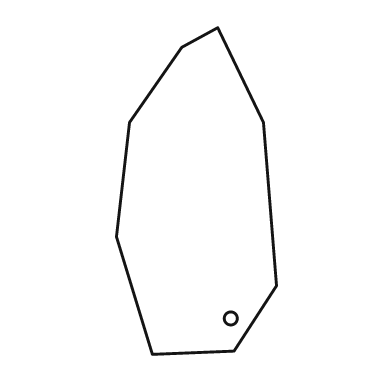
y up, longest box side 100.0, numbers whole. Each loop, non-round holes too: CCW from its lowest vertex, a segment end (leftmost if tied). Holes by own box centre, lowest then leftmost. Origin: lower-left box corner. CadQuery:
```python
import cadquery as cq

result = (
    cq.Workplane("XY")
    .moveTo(11.0, 0.0)
    .lineTo(36.0, 1.0)
    .lineTo(49.0, 21.0)
    .lineTo(45.0, 71.0)
    .lineTo(31.0, 100.0)
    .lineTo(20.0, 94.0)
    .lineTo(4.0, 71.0)
    .lineTo(0.0, 36.0)
    .close()
    .moveTo(35.0, 11.0)
    .circle(2.0)
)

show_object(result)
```